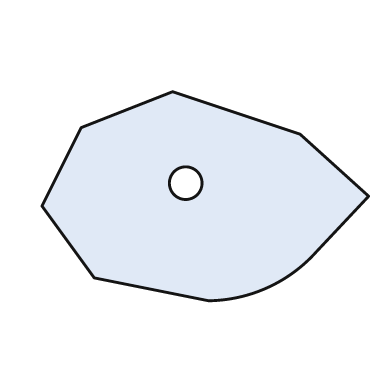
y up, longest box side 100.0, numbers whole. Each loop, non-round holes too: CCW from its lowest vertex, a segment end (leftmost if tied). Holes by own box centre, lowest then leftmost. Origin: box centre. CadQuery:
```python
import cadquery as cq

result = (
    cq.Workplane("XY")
    .moveTo(1.0, -32.0)
    .threePointArc((19.0, -28.0), (34.0, -17.0))
    .lineTo(50.0, 0.0)
    .lineTo(29.0, 19.0)
    .lineTo(-10.0, 32.0)
    .lineTo(-38.0, 21.0)
    .lineTo(-50.0, -3.0)
    .lineTo(-34.0, -25.0)
    .close()
    .moveTo(-6.0, 4.0)
    .circle(5.0)
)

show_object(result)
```